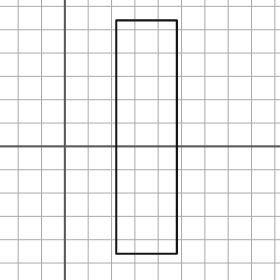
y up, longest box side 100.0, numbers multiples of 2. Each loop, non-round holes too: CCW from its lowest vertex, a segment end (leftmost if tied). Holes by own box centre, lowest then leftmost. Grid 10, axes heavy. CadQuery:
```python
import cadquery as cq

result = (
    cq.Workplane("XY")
    .moveTo(22.0, -46.0)
    .lineTo(48.0, -46.0)
    .lineTo(48.0, 54.0)
    .lineTo(22.0, 54.0)
    .close()
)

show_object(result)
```